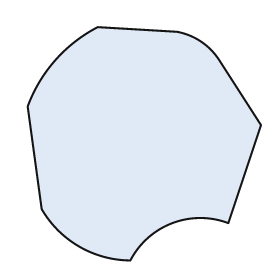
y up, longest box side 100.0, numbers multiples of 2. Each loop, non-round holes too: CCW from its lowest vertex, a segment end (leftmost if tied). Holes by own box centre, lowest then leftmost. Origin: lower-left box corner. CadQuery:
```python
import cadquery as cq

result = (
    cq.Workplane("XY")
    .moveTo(44.0, 0.0)
    .threePointArc((62.0, 16.0), (86.0, 16.0))
    .lineTo(100.0, 58.0)
    .lineTo(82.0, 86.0)
    .threePointArc((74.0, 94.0), (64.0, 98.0))
    .lineTo(30.0, 100.0)
    .threePointArc((12.0, 86.0), (0.0, 66.0))
    .lineTo(6.0, 22.0)
    .threePointArc((22.0, 6.0), (44.0, 0.0))
    .close()
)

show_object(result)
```